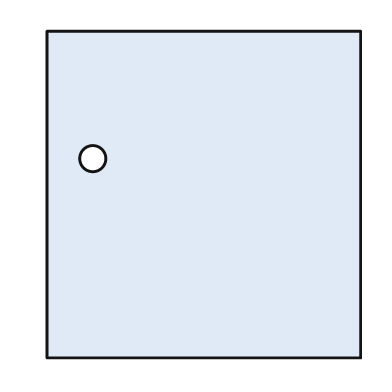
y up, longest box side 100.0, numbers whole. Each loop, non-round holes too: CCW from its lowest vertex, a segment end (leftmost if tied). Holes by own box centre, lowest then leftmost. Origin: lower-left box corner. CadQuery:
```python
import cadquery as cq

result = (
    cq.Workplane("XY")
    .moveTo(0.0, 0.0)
    .lineTo(96.0, 0.0)
    .lineTo(96.0, 100.0)
    .lineTo(0.0, 100.0)
    .close()
    .moveTo(14.0, 61.0)
    .circle(4.0)
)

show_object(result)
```